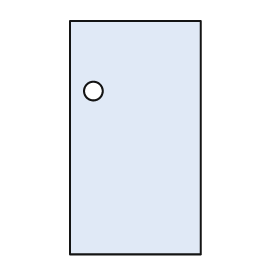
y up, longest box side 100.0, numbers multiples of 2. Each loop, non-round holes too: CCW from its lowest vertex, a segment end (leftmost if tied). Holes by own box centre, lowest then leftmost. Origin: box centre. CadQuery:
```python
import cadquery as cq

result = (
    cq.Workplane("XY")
    .moveTo(-28.0, -50.0)
    .lineTo(28.0, -50.0)
    .lineTo(28.0, 50.0)
    .lineTo(-28.0, 50.0)
    .close()
    .moveTo(-18.0, 20.0)
    .circle(4.0)
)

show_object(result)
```